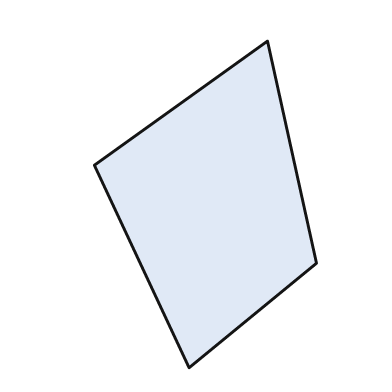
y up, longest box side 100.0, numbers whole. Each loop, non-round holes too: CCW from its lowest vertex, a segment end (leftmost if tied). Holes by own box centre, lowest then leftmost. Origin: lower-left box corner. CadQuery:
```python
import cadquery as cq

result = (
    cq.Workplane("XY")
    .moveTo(29.0, 0.0)
    .lineTo(68.0, 32.0)
    .lineTo(53.0, 100.0)
    .lineTo(0.0, 62.0)
    .close()
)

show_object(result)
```